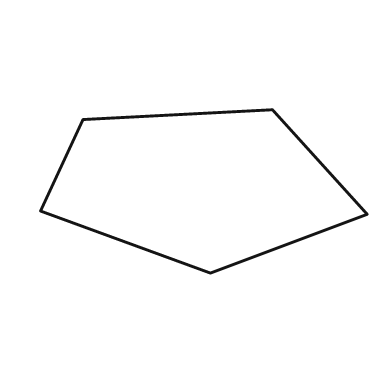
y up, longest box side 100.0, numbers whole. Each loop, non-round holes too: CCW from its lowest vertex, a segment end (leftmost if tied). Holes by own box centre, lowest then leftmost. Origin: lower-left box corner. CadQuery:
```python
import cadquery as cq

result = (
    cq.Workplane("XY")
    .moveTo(52.0, 0.0)
    .lineTo(100.0, 18.0)
    .lineTo(71.0, 50.0)
    .lineTo(13.0, 47.0)
    .lineTo(0.0, 19.0)
    .close()
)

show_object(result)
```